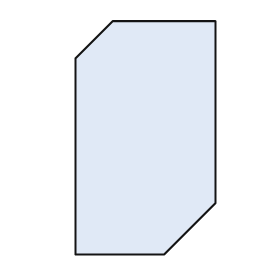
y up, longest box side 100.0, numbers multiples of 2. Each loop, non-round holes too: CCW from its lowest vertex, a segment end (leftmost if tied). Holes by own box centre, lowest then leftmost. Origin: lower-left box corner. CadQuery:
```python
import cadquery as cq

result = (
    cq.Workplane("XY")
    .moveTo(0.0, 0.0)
    .lineTo(38.0, 0.0)
    .lineTo(60.0, 22.0)
    .lineTo(60.0, 100.0)
    .lineTo(16.0, 100.0)
    .lineTo(0.0, 84.0)
    .close()
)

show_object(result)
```